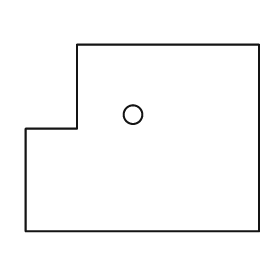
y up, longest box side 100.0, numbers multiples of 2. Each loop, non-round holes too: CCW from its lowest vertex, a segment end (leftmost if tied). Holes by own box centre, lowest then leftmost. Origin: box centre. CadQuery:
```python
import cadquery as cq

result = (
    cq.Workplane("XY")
    .moveTo(-50.0, -40.0)
    .lineTo(50.0, -40.0)
    .lineTo(50.0, 40.0)
    .lineTo(-28.0, 40.0)
    .lineTo(-28.0, 4.0)
    .lineTo(-50.0, 4.0)
    .close()
    .moveTo(-4.0, 10.0)
    .circle(4.0)
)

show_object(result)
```